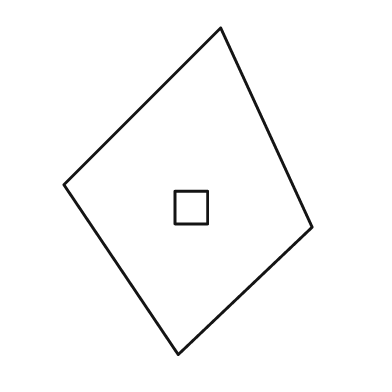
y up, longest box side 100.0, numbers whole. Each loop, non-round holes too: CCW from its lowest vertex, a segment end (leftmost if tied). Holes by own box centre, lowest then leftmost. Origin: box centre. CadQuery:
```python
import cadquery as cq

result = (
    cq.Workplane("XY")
    .moveTo(-3.0, -50.0)
    .lineTo(38.0, -11.0)
    .lineTo(10.0, 50.0)
    .lineTo(-38.0, 2.0)
    .close()
    .moveTo(-4.0, -10.0)
    .lineTo(6.0, -10.0)
    .lineTo(6.0, 0.0)
    .lineTo(-4.0, 0.0)
    .close()
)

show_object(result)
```